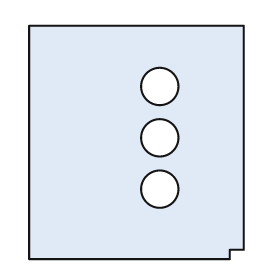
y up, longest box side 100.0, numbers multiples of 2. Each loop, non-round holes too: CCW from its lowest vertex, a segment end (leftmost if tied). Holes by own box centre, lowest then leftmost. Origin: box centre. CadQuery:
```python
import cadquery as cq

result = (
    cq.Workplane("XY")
    .moveTo(-46.0, -50.0)
    .lineTo(40.0, -50.0)
    .lineTo(40.0, -46.0)
    .lineTo(46.0, -46.0)
    .lineTo(46.0, 50.0)
    .lineTo(-46.0, 50.0)
    .close()
    .moveTo(10.0, -20.0)
    .circle(8.0)
    .moveTo(10.0, 2.0)
    .circle(8.0)
    .moveTo(10.0, 24.0)
    .circle(8.0)
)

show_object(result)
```